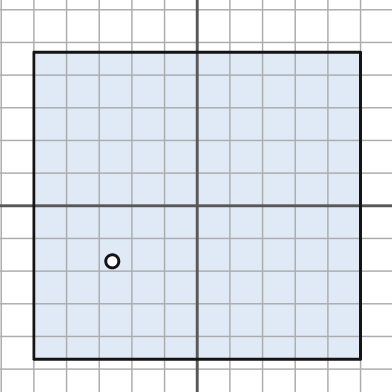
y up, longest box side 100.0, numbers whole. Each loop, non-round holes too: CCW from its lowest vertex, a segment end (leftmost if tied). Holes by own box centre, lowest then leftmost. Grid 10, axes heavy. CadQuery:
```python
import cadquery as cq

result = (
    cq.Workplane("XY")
    .moveTo(-50.0, -47.0)
    .lineTo(50.0, -47.0)
    .lineTo(50.0, 47.0)
    .lineTo(-50.0, 47.0)
    .close()
    .moveTo(-26.0, -17.0)
    .circle(2.0)
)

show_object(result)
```